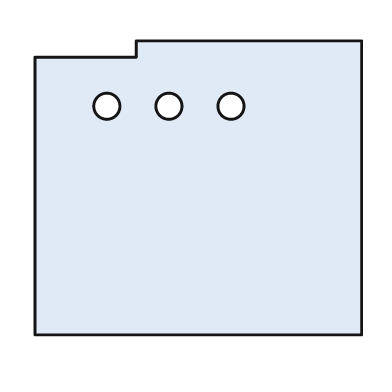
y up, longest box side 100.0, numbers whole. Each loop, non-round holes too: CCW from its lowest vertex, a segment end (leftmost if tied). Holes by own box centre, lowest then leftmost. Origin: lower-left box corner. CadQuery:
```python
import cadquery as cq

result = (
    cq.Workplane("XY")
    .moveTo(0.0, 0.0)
    .lineTo(100.0, 0.0)
    .lineTo(100.0, 90.0)
    .lineTo(31.0, 90.0)
    .lineTo(31.0, 85.0)
    .lineTo(0.0, 85.0)
    .close()
    .moveTo(22.0, 70.0)
    .circle(4.0)
    .moveTo(41.0, 70.0)
    .circle(4.0)
    .moveTo(60.0, 70.0)
    .circle(4.0)
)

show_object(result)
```